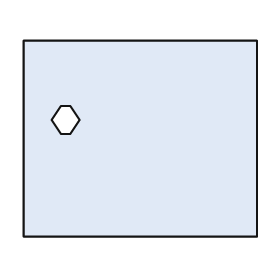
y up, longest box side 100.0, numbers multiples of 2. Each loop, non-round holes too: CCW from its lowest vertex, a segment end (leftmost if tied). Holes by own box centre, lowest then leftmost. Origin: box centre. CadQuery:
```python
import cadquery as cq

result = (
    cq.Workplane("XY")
    .moveTo(-50.0, -42.0)
    .lineTo(50.0, -42.0)
    .lineTo(50.0, 42.0)
    .lineTo(-50.0, 42.0)
    .close()
    .moveTo(-34.0, 2.0)
    .lineTo(-30.0, 2.0)
    .lineTo(-26.0, 8.0)
    .lineTo(-30.0, 14.0)
    .lineTo(-34.0, 14.0)
    .lineTo(-38.0, 8.0)
    .close()
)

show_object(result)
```